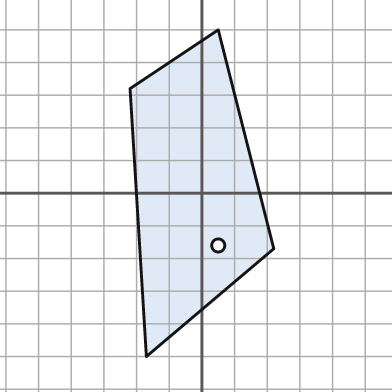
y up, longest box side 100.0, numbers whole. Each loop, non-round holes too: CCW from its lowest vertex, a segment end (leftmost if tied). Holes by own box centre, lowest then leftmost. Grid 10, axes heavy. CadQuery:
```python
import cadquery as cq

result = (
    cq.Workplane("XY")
    .moveTo(-17.0, -50.0)
    .lineTo(22.0, -17.0)
    .lineTo(5.0, 50.0)
    .lineTo(-22.0, 32.0)
    .close()
    .moveTo(5.0, -16.0)
    .circle(2.0)
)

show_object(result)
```